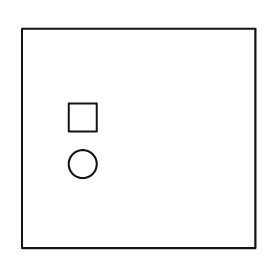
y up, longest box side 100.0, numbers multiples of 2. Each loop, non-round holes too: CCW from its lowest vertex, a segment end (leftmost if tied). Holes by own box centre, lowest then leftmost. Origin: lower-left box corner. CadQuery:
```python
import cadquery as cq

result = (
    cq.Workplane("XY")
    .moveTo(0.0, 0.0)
    .lineTo(100.0, 0.0)
    .lineTo(100.0, 94.0)
    .lineTo(0.0, 94.0)
    .close()
    .moveTo(26.0, 36.0)
    .circle(6.0)
    .moveTo(20.0, 50.0)
    .lineTo(32.0, 50.0)
    .lineTo(32.0, 62.0)
    .lineTo(20.0, 62.0)
    .close()
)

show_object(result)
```